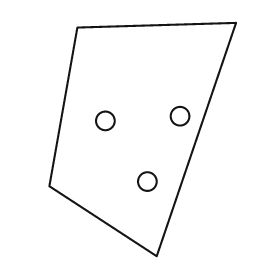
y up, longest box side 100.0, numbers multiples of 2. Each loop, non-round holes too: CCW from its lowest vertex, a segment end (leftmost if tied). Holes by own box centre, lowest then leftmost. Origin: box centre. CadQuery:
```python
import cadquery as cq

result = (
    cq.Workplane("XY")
    .moveTo(6.0, -50.0)
    .lineTo(40.0, 50.0)
    .lineTo(-28.0, 48.0)
    .lineTo(-40.0, -20.0)
    .close()
    .moveTo(2.0, -18.0)
    .circle(4.0)
    .moveTo(-16.0, 8.0)
    .circle(4.0)
    .moveTo(16.0, 10.0)
    .circle(4.0)
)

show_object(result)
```